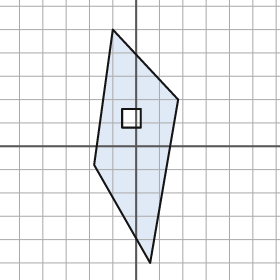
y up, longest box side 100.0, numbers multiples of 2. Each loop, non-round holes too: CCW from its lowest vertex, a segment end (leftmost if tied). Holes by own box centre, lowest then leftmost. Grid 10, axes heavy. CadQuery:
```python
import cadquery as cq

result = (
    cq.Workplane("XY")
    .moveTo(6.0, -50.0)
    .lineTo(18.0, 20.0)
    .lineTo(-10.0, 50.0)
    .lineTo(-18.0, -8.0)
    .close()
    .moveTo(-6.0, 8.0)
    .lineTo(2.0, 8.0)
    .lineTo(2.0, 16.0)
    .lineTo(-6.0, 16.0)
    .close()
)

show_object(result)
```